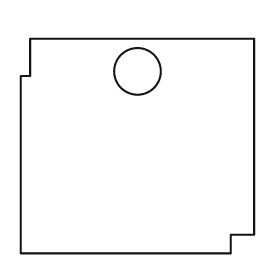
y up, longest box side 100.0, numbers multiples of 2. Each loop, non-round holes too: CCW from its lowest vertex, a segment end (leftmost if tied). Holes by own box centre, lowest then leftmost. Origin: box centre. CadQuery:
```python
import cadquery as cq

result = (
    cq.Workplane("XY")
    .moveTo(-50.0, -46.0)
    .lineTo(40.0, -46.0)
    .lineTo(40.0, -38.0)
    .lineTo(50.0, -38.0)
    .lineTo(50.0, 46.0)
    .lineTo(-46.0, 46.0)
    .lineTo(-46.0, 30.0)
    .lineTo(-50.0, 30.0)
    .close()
    .moveTo(0.0, 32.0)
    .circle(10.0)
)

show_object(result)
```